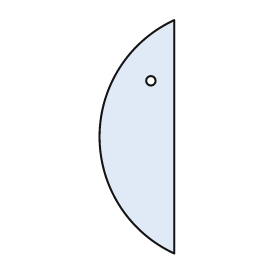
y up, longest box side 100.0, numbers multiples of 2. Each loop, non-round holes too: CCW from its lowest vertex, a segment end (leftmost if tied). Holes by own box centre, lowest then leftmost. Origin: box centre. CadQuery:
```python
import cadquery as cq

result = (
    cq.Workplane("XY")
    .moveTo(16.0, -50.0)
    .lineTo(16.0, 50.0)
    .threePointArc((-16.0, 0.0), (16.0, -50.0))
    .close()
    .moveTo(6.0, 24.0)
    .circle(2.0)
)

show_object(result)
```